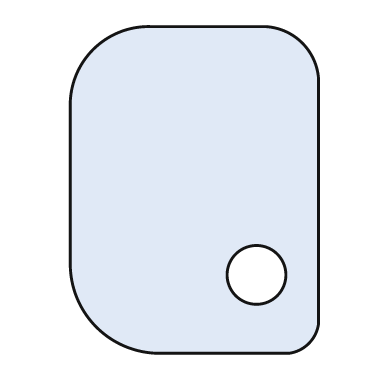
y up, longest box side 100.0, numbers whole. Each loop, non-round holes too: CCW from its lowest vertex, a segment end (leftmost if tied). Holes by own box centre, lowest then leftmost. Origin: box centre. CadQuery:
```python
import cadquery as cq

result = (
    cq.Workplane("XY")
    .moveTo(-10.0, -50.0)
    .lineTo(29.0, -50.0)
    .threePointArc((35.0, -47.0), (38.0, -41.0))
    .lineTo(38.0, 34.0)
    .threePointArc((33.0, 45.0), (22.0, 50.0))
    .lineTo(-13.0, 50.0)
    .threePointArc((-31.0, 43.0), (-38.0, 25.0))
    .lineTo(-38.0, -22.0)
    .threePointArc((-30.0, -42.0), (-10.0, -50.0))
    .close()
    .moveTo(19.0, -26.0)
    .circle(9.0)
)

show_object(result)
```